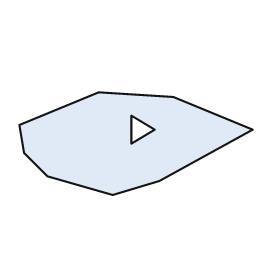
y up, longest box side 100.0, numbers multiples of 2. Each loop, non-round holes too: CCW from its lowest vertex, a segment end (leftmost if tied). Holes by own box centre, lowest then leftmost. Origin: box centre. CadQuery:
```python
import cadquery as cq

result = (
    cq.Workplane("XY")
    .moveTo(-10.0, -22.0)
    .lineTo(10.0, -16.0)
    .lineTo(50.0, 6.0)
    .lineTo(16.0, 20.0)
    .lineTo(-16.0, 22.0)
    .lineTo(-50.0, 8.0)
    .lineTo(-48.0, -4.0)
    .lineTo(-38.0, -14.0)
    .close()
    .moveTo(-2.0, 0.0)
    .lineTo(8.0, 6.0)
    .lineTo(-2.0, 12.0)
    .close()
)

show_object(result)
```